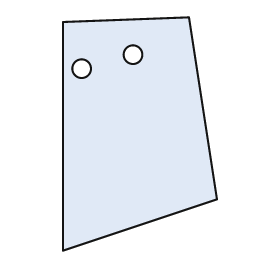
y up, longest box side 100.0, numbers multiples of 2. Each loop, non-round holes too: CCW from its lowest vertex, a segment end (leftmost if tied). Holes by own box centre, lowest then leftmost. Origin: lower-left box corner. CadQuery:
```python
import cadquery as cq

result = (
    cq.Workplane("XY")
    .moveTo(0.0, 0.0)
    .lineTo(66.0, 22.0)
    .lineTo(54.0, 100.0)
    .lineTo(0.0, 98.0)
    .close()
    .moveTo(8.0, 78.0)
    .circle(4.0)
    .moveTo(30.0, 84.0)
    .circle(4.0)
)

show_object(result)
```